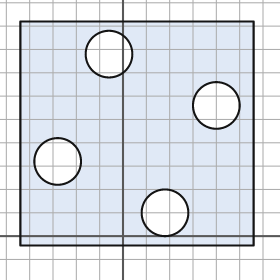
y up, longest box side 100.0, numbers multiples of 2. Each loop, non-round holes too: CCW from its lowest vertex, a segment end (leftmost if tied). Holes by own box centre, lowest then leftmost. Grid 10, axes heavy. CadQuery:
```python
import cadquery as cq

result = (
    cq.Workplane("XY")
    .moveTo(-44.0, -4.0)
    .lineTo(56.0, -4.0)
    .lineTo(56.0, 92.0)
    .lineTo(-44.0, 92.0)
    .close()
    .moveTo(18.0, 10.0)
    .circle(10.0)
    .moveTo(-28.0, 32.0)
    .circle(10.0)
    .moveTo(40.0, 56.0)
    .circle(10.0)
    .moveTo(-6.0, 78.0)
    .circle(10.0)
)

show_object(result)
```